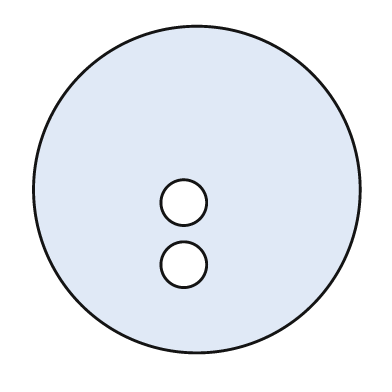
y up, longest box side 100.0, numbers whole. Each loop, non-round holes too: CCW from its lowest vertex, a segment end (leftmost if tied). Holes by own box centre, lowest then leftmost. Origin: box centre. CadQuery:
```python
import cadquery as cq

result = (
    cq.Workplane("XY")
    .moveTo(0.0, 0.0)
    .circle(50.0)
    .moveTo(-4.0, -23.0)
    .circle(7.0)
    .moveTo(-4.0, -4.0)
    .circle(7.0)
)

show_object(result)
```